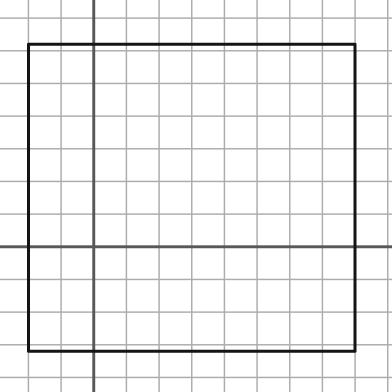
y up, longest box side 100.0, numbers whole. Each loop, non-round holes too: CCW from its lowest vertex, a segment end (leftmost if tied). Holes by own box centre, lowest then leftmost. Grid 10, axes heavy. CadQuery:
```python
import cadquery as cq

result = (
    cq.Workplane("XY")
    .moveTo(-20.0, -32.0)
    .lineTo(80.0, -32.0)
    .lineTo(80.0, 62.0)
    .lineTo(-20.0, 62.0)
    .close()
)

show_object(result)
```